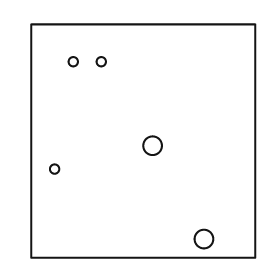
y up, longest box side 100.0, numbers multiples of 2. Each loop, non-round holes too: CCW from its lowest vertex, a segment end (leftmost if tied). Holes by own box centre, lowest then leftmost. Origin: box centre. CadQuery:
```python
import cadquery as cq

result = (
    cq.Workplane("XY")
    .moveTo(-48.0, -50.0)
    .lineTo(48.0, -50.0)
    .lineTo(48.0, 50.0)
    .lineTo(-48.0, 50.0)
    .close()
    .moveTo(26.0, -42.0)
    .circle(4.0)
    .moveTo(-38.0, -12.0)
    .circle(2.0)
    .moveTo(4.0, -2.0)
    .circle(4.0)
    .moveTo(-30.0, 34.0)
    .circle(2.0)
    .moveTo(-18.0, 34.0)
    .circle(2.0)
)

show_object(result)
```